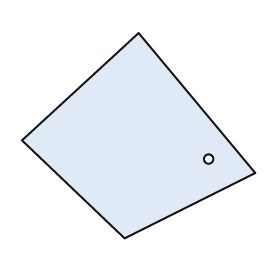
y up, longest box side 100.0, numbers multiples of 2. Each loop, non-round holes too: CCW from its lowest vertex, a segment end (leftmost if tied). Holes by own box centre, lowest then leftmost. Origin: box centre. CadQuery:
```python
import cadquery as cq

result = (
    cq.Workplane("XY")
    .moveTo(-6.0, -44.0)
    .lineTo(50.0, -16.0)
    .lineTo(0.0, 44.0)
    .lineTo(-50.0, -2.0)
    .close()
    .moveTo(30.0, -10.0)
    .circle(2.0)
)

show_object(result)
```